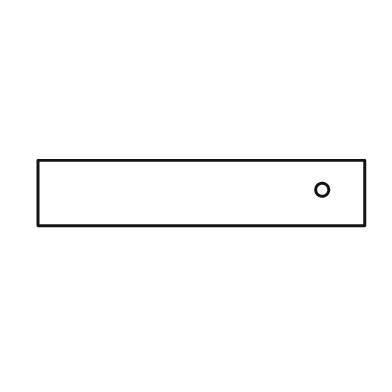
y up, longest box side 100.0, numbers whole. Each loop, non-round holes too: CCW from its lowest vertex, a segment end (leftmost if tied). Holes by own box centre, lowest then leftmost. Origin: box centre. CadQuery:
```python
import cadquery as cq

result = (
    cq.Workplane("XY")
    .moveTo(-50.0, -10.0)
    .lineTo(50.0, -10.0)
    .lineTo(50.0, 10.0)
    .lineTo(-50.0, 10.0)
    .close()
    .moveTo(37.0, 1.0)
    .circle(2.0)
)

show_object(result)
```